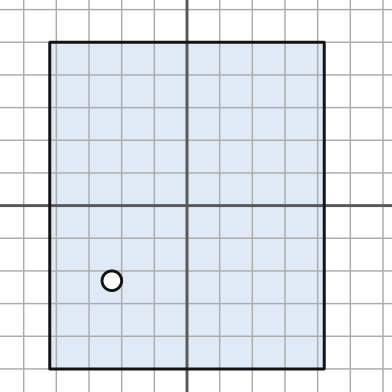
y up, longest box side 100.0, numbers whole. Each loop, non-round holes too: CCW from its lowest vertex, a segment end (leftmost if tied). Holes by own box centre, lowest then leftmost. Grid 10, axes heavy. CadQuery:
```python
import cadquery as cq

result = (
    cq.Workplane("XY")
    .moveTo(-42.0, -50.0)
    .lineTo(42.0, -50.0)
    .lineTo(42.0, 50.0)
    .lineTo(-42.0, 50.0)
    .close()
    .moveTo(-23.0, -23.0)
    .circle(3.0)
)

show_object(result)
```